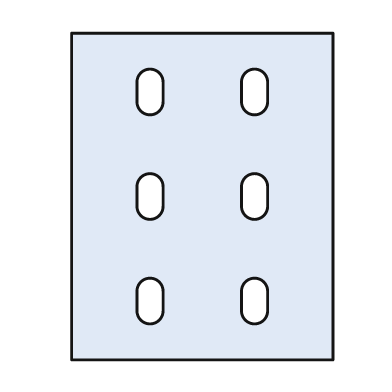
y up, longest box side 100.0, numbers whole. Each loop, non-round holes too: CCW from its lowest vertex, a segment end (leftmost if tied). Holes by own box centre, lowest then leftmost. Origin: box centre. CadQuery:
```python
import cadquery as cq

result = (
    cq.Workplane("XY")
    .moveTo(-40.0, -50.0)
    .lineTo(40.0, -50.0)
    .lineTo(40.0, 50.0)
    .lineTo(-40.0, 50.0)
    .close()
    .moveTo(-20.0, -35.0)
    .threePointArc((-16.0, -39.0), (-12.0, -35.0))
    .lineTo(-12.0, -29.0)
    .threePointArc((-16.0, -25.0), (-20.0, -29.0))
    .close()
    .moveTo(12.0, -35.0)
    .threePointArc((16.0, -39.0), (20.0, -35.0))
    .lineTo(20.0, -29.0)
    .threePointArc((16.0, -25.0), (12.0, -29.0))
    .close()
    .moveTo(-20.0, -3.0)
    .threePointArc((-16.0, -7.0), (-12.0, -3.0))
    .lineTo(-12.0, 3.0)
    .threePointArc((-16.0, 7.0), (-20.0, 3.0))
    .close()
    .moveTo(12.0, -3.0)
    .threePointArc((16.0, -7.0), (20.0, -3.0))
    .lineTo(20.0, 3.0)
    .threePointArc((16.0, 7.0), (12.0, 3.0))
    .close()
    .moveTo(-20.0, 29.0)
    .threePointArc((-16.0, 25.0), (-12.0, 29.0))
    .lineTo(-12.0, 35.0)
    .threePointArc((-16.0, 39.0), (-20.0, 35.0))
    .close()
    .moveTo(12.0, 29.0)
    .threePointArc((16.0, 25.0), (20.0, 29.0))
    .lineTo(20.0, 35.0)
    .threePointArc((16.0, 39.0), (12.0, 35.0))
    .close()
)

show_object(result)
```